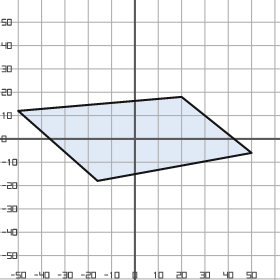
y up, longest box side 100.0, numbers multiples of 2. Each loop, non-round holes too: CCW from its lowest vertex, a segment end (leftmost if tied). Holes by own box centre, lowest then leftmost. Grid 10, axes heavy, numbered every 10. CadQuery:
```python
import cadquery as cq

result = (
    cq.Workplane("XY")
    .moveTo(-16.0, -18.0)
    .lineTo(50.0, -6.0)
    .lineTo(20.0, 18.0)
    .lineTo(-50.0, 12.0)
    .close()
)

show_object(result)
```